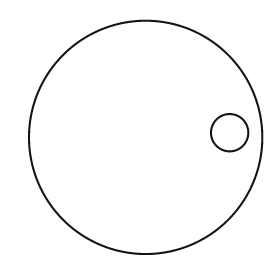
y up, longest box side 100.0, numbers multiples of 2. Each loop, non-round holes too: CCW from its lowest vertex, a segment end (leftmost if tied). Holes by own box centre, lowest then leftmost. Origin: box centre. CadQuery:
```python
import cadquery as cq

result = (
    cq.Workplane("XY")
    .moveTo(0.0, 0.0)
    .circle(50.0)
    .moveTo(36.0, 2.0)
    .circle(8.0)
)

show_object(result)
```